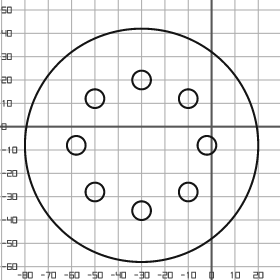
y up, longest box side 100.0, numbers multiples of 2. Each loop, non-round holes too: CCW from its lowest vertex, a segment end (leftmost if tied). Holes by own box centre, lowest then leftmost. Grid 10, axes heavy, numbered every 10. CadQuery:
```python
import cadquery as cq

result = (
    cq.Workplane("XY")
    .moveTo(-30.0, -8.0)
    .circle(50.0)
    .moveTo(-30.0, -36.0)
    .circle(4.0)
    .moveTo(-50.0, -28.0)
    .circle(4.0)
    .moveTo(-10.0, -28.0)
    .circle(4.0)
    .moveTo(-58.0, -8.0)
    .circle(4.0)
    .moveTo(-2.0, -8.0)
    .circle(4.0)
    .moveTo(-50.0, 12.0)
    .circle(4.0)
    .moveTo(-10.0, 12.0)
    .circle(4.0)
    .moveTo(-30.0, 20.0)
    .circle(4.0)
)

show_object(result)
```